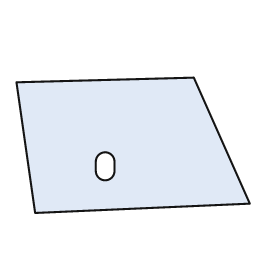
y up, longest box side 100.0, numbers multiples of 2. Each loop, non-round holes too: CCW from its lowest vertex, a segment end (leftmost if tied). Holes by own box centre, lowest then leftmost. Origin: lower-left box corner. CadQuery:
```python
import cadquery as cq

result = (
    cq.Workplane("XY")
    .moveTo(8.0, 0.0)
    .lineTo(100.0, 4.0)
    .lineTo(76.0, 58.0)
    .lineTo(0.0, 56.0)
    .close()
    .moveTo(34.0, 18.0)
    .threePointArc((38.0, 14.0), (42.0, 18.0))
    .lineTo(42.0, 22.0)
    .threePointArc((38.0, 26.0), (34.0, 22.0))
    .close()
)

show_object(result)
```